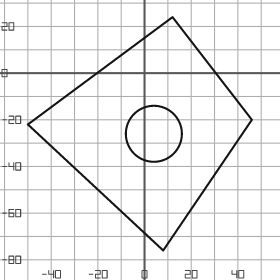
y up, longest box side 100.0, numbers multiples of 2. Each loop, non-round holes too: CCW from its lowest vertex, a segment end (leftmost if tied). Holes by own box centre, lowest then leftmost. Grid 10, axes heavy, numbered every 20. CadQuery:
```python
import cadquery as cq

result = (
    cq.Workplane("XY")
    .moveTo(8.0, -76.0)
    .lineTo(46.0, -20.0)
    .lineTo(12.0, 24.0)
    .lineTo(-50.0, -22.0)
    .close()
    .moveTo(4.0, -26.0)
    .circle(12.0)
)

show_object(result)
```